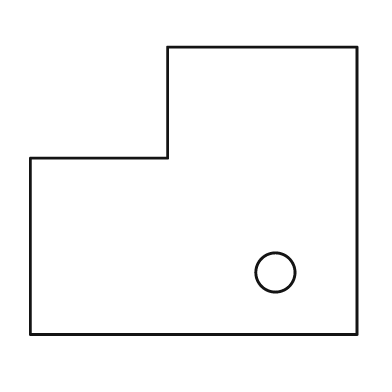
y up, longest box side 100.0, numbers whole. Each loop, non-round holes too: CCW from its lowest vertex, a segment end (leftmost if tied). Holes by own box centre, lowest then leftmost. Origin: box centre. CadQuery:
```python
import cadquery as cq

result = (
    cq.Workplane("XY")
    .moveTo(-50.0, -44.0)
    .lineTo(50.0, -44.0)
    .lineTo(50.0, 44.0)
    .lineTo(-8.0, 44.0)
    .lineTo(-8.0, 10.0)
    .lineTo(-50.0, 10.0)
    .close()
    .moveTo(25.0, -25.0)
    .circle(6.0)
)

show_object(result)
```